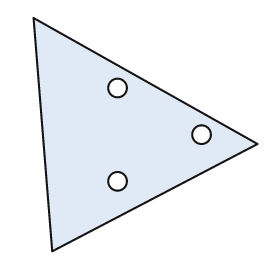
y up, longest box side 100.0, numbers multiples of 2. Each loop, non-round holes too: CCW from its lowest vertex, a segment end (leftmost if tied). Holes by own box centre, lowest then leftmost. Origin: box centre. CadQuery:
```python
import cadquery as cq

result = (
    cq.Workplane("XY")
    .moveTo(-40.0, -50.0)
    .lineTo(48.0, -4.0)
    .lineTo(-48.0, 50.0)
    .close()
    .moveTo(-12.0, -20.0)
    .circle(4.0)
    .moveTo(24.0, 0.0)
    .circle(4.0)
    .moveTo(-12.0, 20.0)
    .circle(4.0)
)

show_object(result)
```